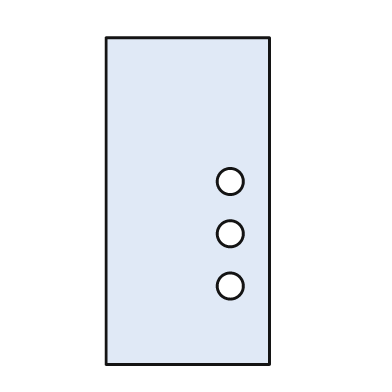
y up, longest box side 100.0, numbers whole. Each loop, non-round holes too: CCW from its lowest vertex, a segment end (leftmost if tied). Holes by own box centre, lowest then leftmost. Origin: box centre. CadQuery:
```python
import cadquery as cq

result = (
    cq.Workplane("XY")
    .moveTo(-25.0, -50.0)
    .lineTo(25.0, -50.0)
    .lineTo(25.0, 50.0)
    .lineTo(-25.0, 50.0)
    .close()
    .moveTo(13.0, -26.0)
    .circle(4.0)
    .moveTo(13.0, -10.0)
    .circle(4.0)
    .moveTo(13.0, 6.0)
    .circle(4.0)
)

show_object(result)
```